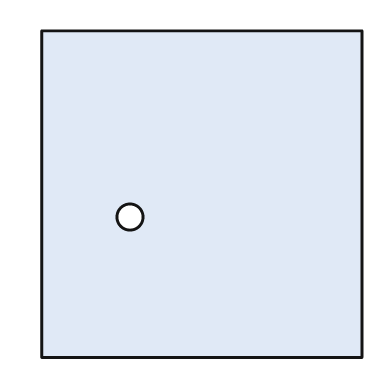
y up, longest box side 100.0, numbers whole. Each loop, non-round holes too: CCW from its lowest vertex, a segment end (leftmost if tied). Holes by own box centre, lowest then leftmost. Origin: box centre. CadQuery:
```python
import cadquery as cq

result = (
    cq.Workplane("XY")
    .moveTo(-49.0, -50.0)
    .lineTo(49.0, -50.0)
    .lineTo(49.0, 50.0)
    .lineTo(-49.0, 50.0)
    .close()
    .moveTo(-22.0, -7.0)
    .circle(4.0)
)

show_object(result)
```